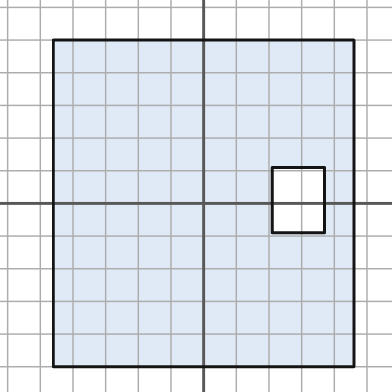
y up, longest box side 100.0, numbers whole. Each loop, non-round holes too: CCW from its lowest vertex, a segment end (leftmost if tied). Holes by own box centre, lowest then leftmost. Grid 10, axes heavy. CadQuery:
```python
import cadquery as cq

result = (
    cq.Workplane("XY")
    .moveTo(-46.0, -50.0)
    .lineTo(46.0, -50.0)
    .lineTo(46.0, 50.0)
    .lineTo(-46.0, 50.0)
    .close()
    .moveTo(21.0, -9.0)
    .lineTo(37.0, -9.0)
    .lineTo(37.0, 11.0)
    .lineTo(21.0, 11.0)
    .close()
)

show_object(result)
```